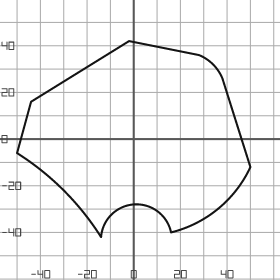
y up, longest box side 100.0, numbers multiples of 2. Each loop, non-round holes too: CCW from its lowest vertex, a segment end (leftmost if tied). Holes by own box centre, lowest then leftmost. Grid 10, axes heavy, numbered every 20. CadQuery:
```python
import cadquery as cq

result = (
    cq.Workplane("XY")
    .moveTo(-14.0, -42.0)
    .threePointArc((0.0, -28.0), (16.0, -40.0))
    .threePointArc((36.0, -30.0), (50.0, -12.0))
    .lineTo(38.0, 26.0)
    .threePointArc((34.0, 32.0), (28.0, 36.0))
    .lineTo(-2.0, 42.0)
    .lineTo(-44.0, 16.0)
    .lineTo(-50.0, -6.0)
    .threePointArc((-30.0, -22.0), (-14.0, -42.0))
    .close()
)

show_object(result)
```